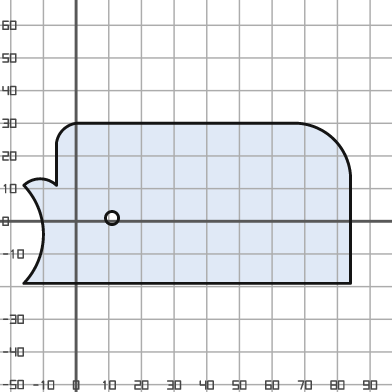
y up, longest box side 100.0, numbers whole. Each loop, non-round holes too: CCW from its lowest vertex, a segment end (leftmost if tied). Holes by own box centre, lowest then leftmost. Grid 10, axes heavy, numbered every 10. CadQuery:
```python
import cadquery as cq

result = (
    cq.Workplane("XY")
    .moveTo(-16.0, -19.0)
    .lineTo(84.0, -19.0)
    .lineTo(84.0, 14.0)
    .threePointArc((79.0, 25.0), (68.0, 30.0))
    .lineTo(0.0, 30.0)
    .threePointArc((-4.0, 28.0), (-6.0, 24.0))
    .lineTo(-6.0, 11.0)
    .threePointArc((-11.0, 13.0), (-16.0, 11.0))
    .threePointArc((-10.0, -4.0), (-16.0, -19.0))
    .close()
    .moveTo(11.0, 1.0)
    .circle(2.0)
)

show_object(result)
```